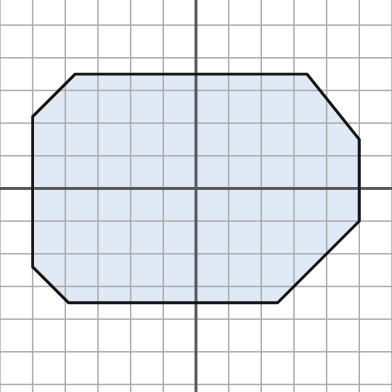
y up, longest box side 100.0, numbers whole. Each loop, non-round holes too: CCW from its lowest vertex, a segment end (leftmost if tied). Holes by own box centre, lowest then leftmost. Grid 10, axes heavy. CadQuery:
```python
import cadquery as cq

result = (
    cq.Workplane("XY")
    .moveTo(-39.0, -35.0)
    .lineTo(25.0, -35.0)
    .lineTo(50.0, -10.0)
    .lineTo(50.0, 15.0)
    .lineTo(34.0, 35.0)
    .lineTo(-37.0, 35.0)
    .lineTo(-50.0, 22.0)
    .lineTo(-50.0, -24.0)
    .close()
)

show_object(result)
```